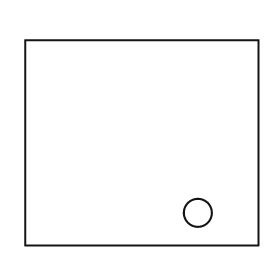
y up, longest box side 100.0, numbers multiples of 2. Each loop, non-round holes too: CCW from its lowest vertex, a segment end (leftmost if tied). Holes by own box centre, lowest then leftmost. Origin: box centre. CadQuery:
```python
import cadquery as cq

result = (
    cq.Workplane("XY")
    .moveTo(-50.0, -44.0)
    .lineTo(50.0, -44.0)
    .lineTo(50.0, 44.0)
    .lineTo(-50.0, 44.0)
    .close()
    .moveTo(24.0, -30.0)
    .circle(6.0)
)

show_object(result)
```